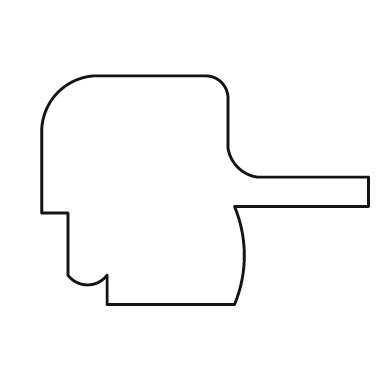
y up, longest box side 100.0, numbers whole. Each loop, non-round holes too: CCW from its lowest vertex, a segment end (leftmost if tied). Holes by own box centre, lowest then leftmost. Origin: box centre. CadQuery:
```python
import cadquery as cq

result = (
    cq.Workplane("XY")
    .moveTo(-30.0, -35.0)
    .lineTo(9.0, -35.0)
    .threePointArc((12.0, -20.0), (9.0, -5.0))
    .lineTo(50.0, -5.0)
    .lineTo(50.0, 4.0)
    .lineTo(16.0, 4.0)
    .threePointArc((10.0, 7.0), (7.0, 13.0))
    .lineTo(7.0, 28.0)
    .threePointArc((5.0, 33.0), (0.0, 35.0))
    .lineTo(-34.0, 35.0)
    .threePointArc((-45.0, 30.0), (-50.0, 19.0))
    .lineTo(-50.0, -7.0)
    .lineTo(-42.0, -7.0)
    .lineTo(-42.0, -26.0)
    .threePointArc((-36.0, -29.0), (-30.0, -26.0))
    .close()
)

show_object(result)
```